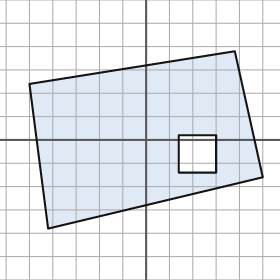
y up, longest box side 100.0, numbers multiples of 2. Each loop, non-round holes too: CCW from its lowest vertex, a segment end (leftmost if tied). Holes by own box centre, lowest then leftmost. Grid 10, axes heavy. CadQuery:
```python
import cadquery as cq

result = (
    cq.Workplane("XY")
    .moveTo(-42.0, -38.0)
    .lineTo(50.0, -16.0)
    .lineTo(38.0, 38.0)
    .lineTo(-50.0, 24.0)
    .close()
    .moveTo(14.0, -14.0)
    .lineTo(30.0, -14.0)
    .lineTo(30.0, 2.0)
    .lineTo(14.0, 2.0)
    .close()
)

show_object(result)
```